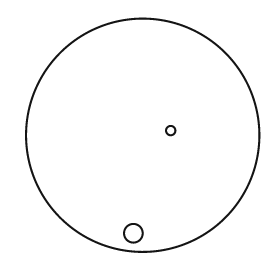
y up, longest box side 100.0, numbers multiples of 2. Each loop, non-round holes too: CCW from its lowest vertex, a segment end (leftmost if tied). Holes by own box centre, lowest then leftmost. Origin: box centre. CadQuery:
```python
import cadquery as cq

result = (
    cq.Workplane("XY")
    .moveTo(0.0, 0.0)
    .circle(50.0)
    .moveTo(-4.0, -42.0)
    .circle(4.0)
    .moveTo(12.0, 2.0)
    .circle(2.0)
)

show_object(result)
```